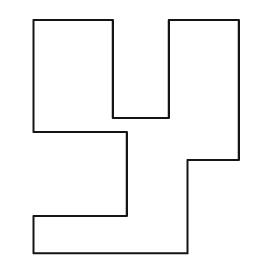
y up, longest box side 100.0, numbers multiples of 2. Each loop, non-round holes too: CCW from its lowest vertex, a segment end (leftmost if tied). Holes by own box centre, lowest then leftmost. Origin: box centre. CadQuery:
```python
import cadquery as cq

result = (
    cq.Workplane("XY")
    .moveTo(-44.0, -50.0)
    .lineTo(22.0, -50.0)
    .lineTo(22.0, -10.0)
    .lineTo(44.0, -10.0)
    .lineTo(44.0, 50.0)
    .lineTo(14.0, 50.0)
    .lineTo(14.0, 8.0)
    .lineTo(-10.0, 8.0)
    .lineTo(-10.0, 50.0)
    .lineTo(-44.0, 50.0)
    .lineTo(-44.0, 2.0)
    .lineTo(-4.0, 2.0)
    .lineTo(-4.0, -34.0)
    .lineTo(-44.0, -34.0)
    .close()
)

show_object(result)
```